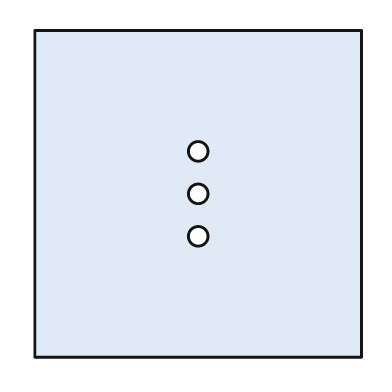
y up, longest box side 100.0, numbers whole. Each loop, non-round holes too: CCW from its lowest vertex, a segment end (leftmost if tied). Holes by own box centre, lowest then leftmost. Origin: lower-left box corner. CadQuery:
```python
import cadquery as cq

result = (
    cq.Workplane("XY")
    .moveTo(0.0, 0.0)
    .lineTo(100.0, 0.0)
    .lineTo(100.0, 100.0)
    .lineTo(0.0, 100.0)
    .close()
    .moveTo(50.0, 37.0)
    .circle(3.0)
    .moveTo(50.0, 50.0)
    .circle(3.0)
    .moveTo(50.0, 63.0)
    .circle(3.0)
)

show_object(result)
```